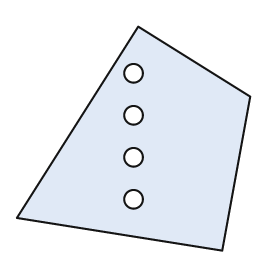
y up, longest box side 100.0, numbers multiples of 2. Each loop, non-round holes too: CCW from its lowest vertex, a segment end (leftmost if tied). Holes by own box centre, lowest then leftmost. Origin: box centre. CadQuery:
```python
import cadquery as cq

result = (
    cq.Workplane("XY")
    .moveTo(38.0, -48.0)
    .lineTo(50.0, 18.0)
    .lineTo(2.0, 48.0)
    .lineTo(-50.0, -34.0)
    .close()
    .moveTo(0.0, -26.0)
    .circle(4.0)
    .moveTo(0.0, -8.0)
    .circle(4.0)
    .moveTo(0.0, 10.0)
    .circle(4.0)
    .moveTo(0.0, 28.0)
    .circle(4.0)
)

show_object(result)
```